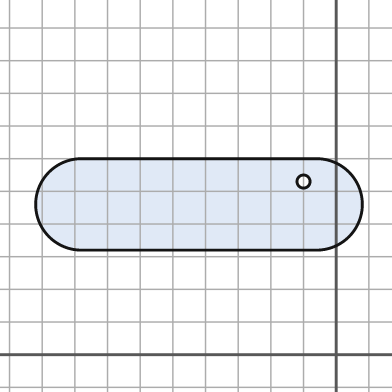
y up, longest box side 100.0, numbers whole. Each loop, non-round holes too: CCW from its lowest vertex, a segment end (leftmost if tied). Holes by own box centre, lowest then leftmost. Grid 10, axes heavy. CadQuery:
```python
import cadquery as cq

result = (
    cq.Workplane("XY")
    .moveTo(-78.0, 32.0)
    .lineTo(-6.0, 32.0)
    .threePointArc((8.0, 46.0), (-6.0, 60.0))
    .lineTo(-78.0, 60.0)
    .threePointArc((-92.0, 46.0), (-78.0, 32.0))
    .close()
    .moveTo(-10.0, 53.0)
    .circle(2.0)
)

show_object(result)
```